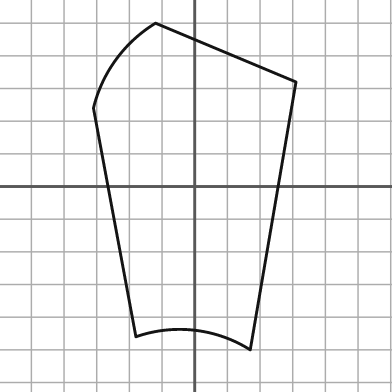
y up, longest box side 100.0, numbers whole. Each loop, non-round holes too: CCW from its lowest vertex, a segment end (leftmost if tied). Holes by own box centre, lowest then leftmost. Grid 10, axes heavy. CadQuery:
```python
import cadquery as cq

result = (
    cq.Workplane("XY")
    .moveTo(17.0, -50.0)
    .lineTo(31.0, 32.0)
    .lineTo(-12.0, 50.0)
    .threePointArc((-24.0, 39.0), (-31.0, 24.0))
    .lineTo(-18.0, -46.0)
    .threePointArc((0.0, -44.0), (17.0, -50.0))
    .close()
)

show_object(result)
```